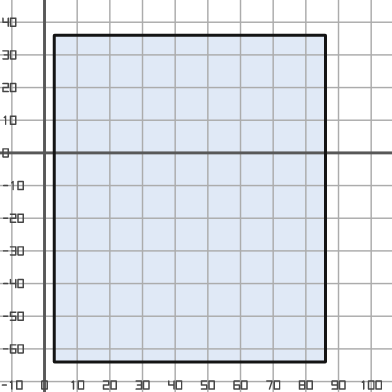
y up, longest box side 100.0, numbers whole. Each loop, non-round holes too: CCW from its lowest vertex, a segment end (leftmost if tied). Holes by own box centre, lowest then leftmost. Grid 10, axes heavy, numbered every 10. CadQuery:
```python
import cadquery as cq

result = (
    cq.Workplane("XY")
    .moveTo(3.0, -64.0)
    .lineTo(86.0, -64.0)
    .lineTo(86.0, 36.0)
    .lineTo(3.0, 36.0)
    .close()
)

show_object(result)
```